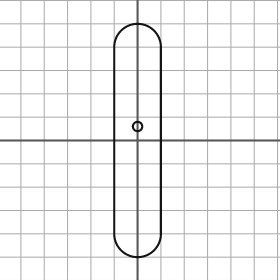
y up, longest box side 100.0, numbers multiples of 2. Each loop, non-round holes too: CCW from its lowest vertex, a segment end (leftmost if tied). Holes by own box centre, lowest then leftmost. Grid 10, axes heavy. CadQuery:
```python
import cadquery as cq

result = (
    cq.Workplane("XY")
    .moveTo(-10.0, -40.0)
    .threePointArc((0.0, -50.0), (10.0, -40.0))
    .lineTo(10.0, 40.0)
    .threePointArc((0.0, 50.0), (-10.0, 40.0))
    .close()
    .moveTo(0.0, 6.0)
    .circle(2.0)
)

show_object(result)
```